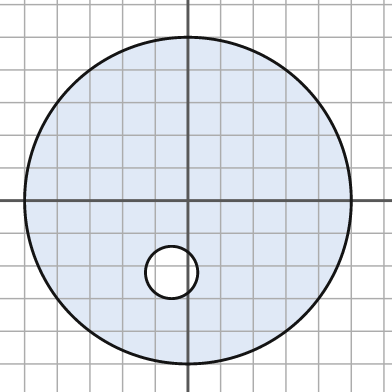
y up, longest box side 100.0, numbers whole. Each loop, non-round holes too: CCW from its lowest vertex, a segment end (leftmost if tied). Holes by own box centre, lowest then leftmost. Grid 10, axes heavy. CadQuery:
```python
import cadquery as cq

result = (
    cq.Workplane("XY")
    .moveTo(0.0, 0.0)
    .circle(50.0)
    .moveTo(-5.0, -22.0)
    .circle(8.0)
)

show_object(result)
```